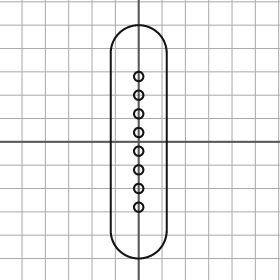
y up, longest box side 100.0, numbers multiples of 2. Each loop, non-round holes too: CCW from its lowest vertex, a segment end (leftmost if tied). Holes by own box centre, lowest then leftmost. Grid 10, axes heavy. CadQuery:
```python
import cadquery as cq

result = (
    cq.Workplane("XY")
    .moveTo(-12.0, -38.0)
    .threePointArc((0.0, -50.0), (12.0, -38.0))
    .lineTo(12.0, 38.0)
    .threePointArc((0.0, 50.0), (-12.0, 38.0))
    .close()
    .moveTo(0.0, -28.0)
    .circle(2.0)
    .moveTo(0.0, -20.0)
    .circle(2.0)
    .moveTo(0.0, -12.0)
    .circle(2.0)
    .moveTo(0.0, -4.0)
    .circle(2.0)
    .moveTo(0.0, 4.0)
    .circle(2.0)
    .moveTo(0.0, 12.0)
    .circle(2.0)
    .moveTo(0.0, 20.0)
    .circle(2.0)
    .moveTo(0.0, 28.0)
    .circle(2.0)
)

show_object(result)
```